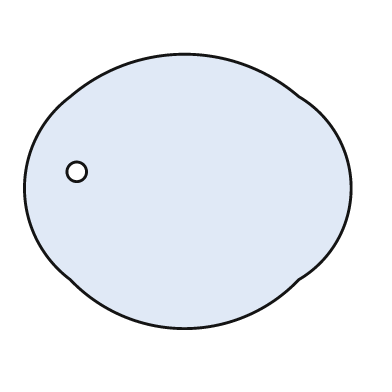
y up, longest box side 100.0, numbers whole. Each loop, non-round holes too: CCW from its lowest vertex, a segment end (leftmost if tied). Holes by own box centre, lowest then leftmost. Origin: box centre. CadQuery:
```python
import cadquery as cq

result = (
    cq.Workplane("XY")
    .moveTo(-36.0, -27.0)
    .threePointArc((-1.0, -42.0), (34.0, -27.0))
    .threePointArc((50.0, 1.0), (34.0, 29.0))
    .threePointArc((-1.0, 42.0), (-36.0, 29.0))
    .threePointArc((-50.0, 1.0), (-36.0, -27.0))
    .close()
    .moveTo(-34.0, 6.0)
    .circle(3.0)
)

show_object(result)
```